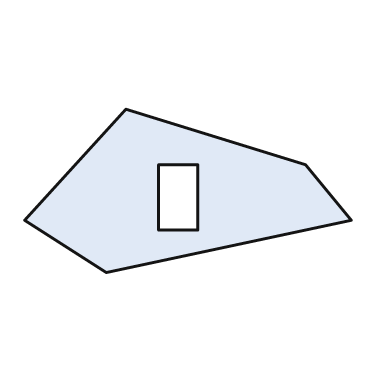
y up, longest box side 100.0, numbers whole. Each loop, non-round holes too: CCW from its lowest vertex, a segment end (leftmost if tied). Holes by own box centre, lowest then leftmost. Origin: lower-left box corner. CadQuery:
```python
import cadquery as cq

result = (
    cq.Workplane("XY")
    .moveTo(25.0, 0.0)
    .lineTo(100.0, 16.0)
    .lineTo(86.0, 33.0)
    .lineTo(31.0, 50.0)
    .lineTo(0.0, 16.0)
    .close()
    .moveTo(41.0, 13.0)
    .lineTo(53.0, 13.0)
    .lineTo(53.0, 33.0)
    .lineTo(41.0, 33.0)
    .close()
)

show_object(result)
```